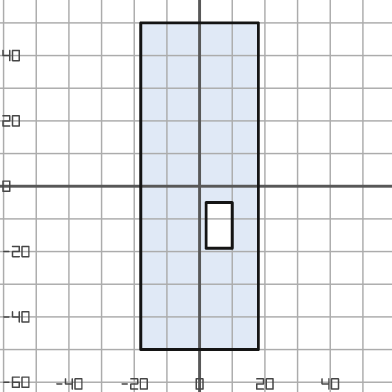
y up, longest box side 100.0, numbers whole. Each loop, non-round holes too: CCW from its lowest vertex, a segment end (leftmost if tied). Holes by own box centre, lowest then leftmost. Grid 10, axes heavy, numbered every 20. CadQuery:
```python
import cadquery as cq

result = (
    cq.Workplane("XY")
    .moveTo(-18.0, -50.0)
    .lineTo(18.0, -50.0)
    .lineTo(18.0, 50.0)
    .lineTo(-18.0, 50.0)
    .close()
    .moveTo(2.0, -19.0)
    .lineTo(10.0, -19.0)
    .lineTo(10.0, -5.0)
    .lineTo(2.0, -5.0)
    .close()
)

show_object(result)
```